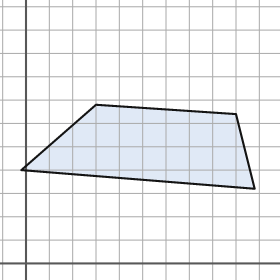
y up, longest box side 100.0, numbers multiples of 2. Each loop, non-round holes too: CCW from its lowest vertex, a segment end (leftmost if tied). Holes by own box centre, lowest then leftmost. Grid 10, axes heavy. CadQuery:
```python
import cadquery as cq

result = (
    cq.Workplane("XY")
    .moveTo(98.0, 32.0)
    .lineTo(90.0, 64.0)
    .lineTo(30.0, 68.0)
    .lineTo(-2.0, 40.0)
    .close()
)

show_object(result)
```